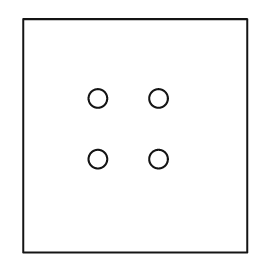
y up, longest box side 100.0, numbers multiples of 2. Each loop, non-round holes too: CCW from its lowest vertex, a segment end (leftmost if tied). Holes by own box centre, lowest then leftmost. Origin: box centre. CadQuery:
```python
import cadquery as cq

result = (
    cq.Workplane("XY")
    .moveTo(-48.0, -50.0)
    .lineTo(48.0, -50.0)
    .lineTo(48.0, 50.0)
    .lineTo(-48.0, 50.0)
    .close()
    .moveTo(-16.0, -10.0)
    .circle(4.0)
    .moveTo(10.0, -10.0)
    .circle(4.0)
    .moveTo(-16.0, 16.0)
    .circle(4.0)
    .moveTo(10.0, 16.0)
    .circle(4.0)
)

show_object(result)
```